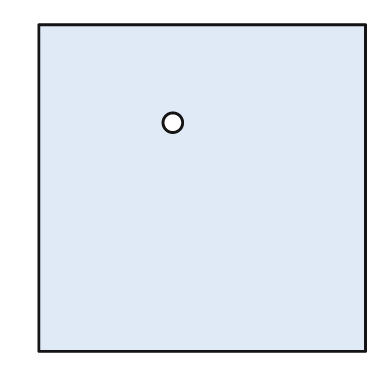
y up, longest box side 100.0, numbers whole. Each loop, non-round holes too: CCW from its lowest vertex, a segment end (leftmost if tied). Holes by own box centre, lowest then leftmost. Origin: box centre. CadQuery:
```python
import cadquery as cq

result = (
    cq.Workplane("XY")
    .moveTo(-50.0, -50.0)
    .lineTo(50.0, -50.0)
    .lineTo(50.0, 50.0)
    .lineTo(-50.0, 50.0)
    .close()
    .moveTo(-9.0, 20.0)
    .circle(3.0)
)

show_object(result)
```